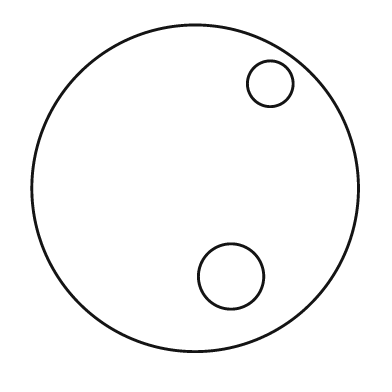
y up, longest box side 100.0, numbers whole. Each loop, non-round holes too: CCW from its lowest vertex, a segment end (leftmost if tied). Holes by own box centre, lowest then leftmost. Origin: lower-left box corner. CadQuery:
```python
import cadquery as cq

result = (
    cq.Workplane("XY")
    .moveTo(50.0, 50.0)
    .circle(50.0)
    .moveTo(61.0, 23.0)
    .circle(10.0)
    .moveTo(73.0, 82.0)
    .circle(7.0)
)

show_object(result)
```